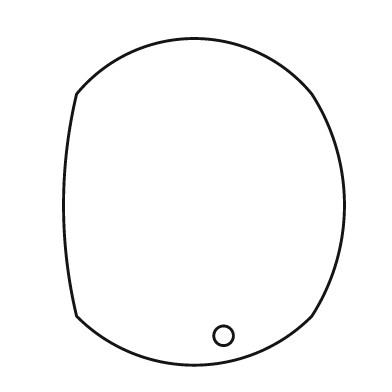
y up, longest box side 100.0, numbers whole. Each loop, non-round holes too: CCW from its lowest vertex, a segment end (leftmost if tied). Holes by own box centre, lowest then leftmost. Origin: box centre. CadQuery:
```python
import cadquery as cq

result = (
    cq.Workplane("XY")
    .moveTo(-39.0, -35.0)
    .threePointArc((-3.0, -50.0), (33.0, -35.0))
    .threePointArc((43.0, -1.0), (33.0, 33.0))
    .threePointArc((-3.0, 50.0), (-39.0, 33.0))
    .threePointArc((-43.0, -1.0), (-39.0, -35.0))
    .close()
    .moveTo(6.0, -41.0)
    .circle(3.0)
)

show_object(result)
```